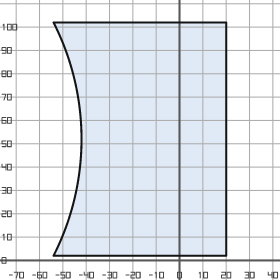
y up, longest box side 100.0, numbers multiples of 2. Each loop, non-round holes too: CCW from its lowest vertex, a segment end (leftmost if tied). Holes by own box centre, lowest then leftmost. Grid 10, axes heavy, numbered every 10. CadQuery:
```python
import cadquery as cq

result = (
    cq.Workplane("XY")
    .moveTo(-54.0, 2.0)
    .lineTo(20.0, 2.0)
    .lineTo(20.0, 102.0)
    .lineTo(-54.0, 102.0)
    .threePointArc((-42.0, 52.0), (-54.0, 2.0))
    .close()
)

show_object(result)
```